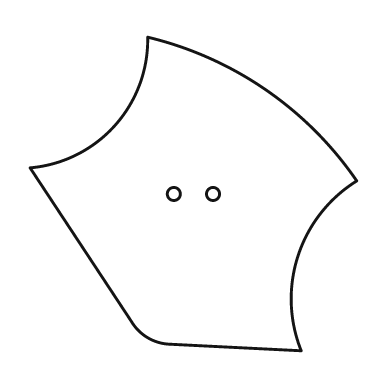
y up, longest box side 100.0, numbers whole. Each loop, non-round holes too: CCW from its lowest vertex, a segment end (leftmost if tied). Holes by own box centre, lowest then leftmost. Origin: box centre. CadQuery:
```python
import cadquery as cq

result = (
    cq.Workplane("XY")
    .moveTo(33.0, -48.0)
    .threePointArc((32.0, -19.0), (50.0, 4.0))
    .threePointArc((22.0, 32.0), (-14.0, 48.0))
    .threePointArc((-24.0, 21.0), (-50.0, 8.0))
    .lineTo(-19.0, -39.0)
    .threePointArc((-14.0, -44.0), (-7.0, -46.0))
    .close()
    .moveTo(-6.0, 0.0)
    .circle(2.0)
    .moveTo(6.0, 0.0)
    .circle(2.0)
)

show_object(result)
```